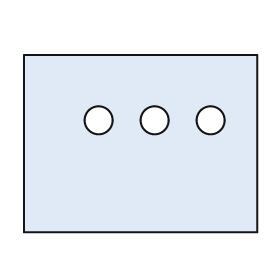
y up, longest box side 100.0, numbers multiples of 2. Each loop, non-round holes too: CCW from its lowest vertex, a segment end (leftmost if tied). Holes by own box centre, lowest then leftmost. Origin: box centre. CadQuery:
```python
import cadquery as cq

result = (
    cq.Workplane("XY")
    .moveTo(-50.0, -38.0)
    .lineTo(50.0, -38.0)
    .lineTo(50.0, 38.0)
    .lineTo(-50.0, 38.0)
    .close()
    .moveTo(-18.0, 10.0)
    .circle(6.0)
    .moveTo(6.0, 10.0)
    .circle(6.0)
    .moveTo(30.0, 10.0)
    .circle(6.0)
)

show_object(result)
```